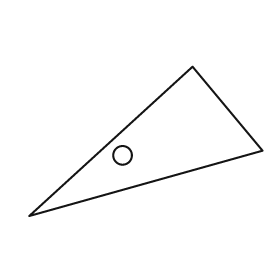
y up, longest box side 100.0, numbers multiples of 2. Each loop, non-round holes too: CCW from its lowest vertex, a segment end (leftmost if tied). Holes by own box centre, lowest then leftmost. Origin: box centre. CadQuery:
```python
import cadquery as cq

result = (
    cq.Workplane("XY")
    .moveTo(-50.0, -32.0)
    .lineTo(50.0, -4.0)
    .lineTo(20.0, 32.0)
    .close()
    .moveTo(-10.0, -6.0)
    .circle(4.0)
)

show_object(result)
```